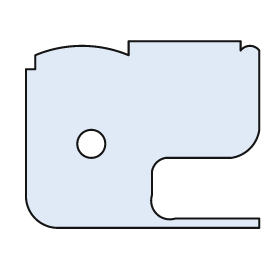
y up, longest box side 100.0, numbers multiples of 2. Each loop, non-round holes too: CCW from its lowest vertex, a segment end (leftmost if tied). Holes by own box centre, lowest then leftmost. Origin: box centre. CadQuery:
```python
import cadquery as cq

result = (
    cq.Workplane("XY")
    .moveTo(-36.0, -40.0)
    .lineTo(50.0, -40.0)
    .lineTo(50.0, -36.0)
    .lineTo(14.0, -36.0)
    .threePointArc((6.0, -34.0), (4.0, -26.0))
    .lineTo(4.0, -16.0)
    .threePointArc((6.0, -12.0), (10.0, -10.0))
    .lineTo(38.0, -10.0)
    .threePointArc((46.0, -6.0), (50.0, 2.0))
    .lineTo(50.0, 36.0)
    .threePointArc((46.0, 38.0), (42.0, 36.0))
    .lineTo(42.0, 40.0)
    .lineTo(-6.0, 40.0)
    .lineTo(-6.0, 34.0)
    .threePointArc((-26.0, 38.0), (-46.0, 34.0))
    .lineTo(-46.0, 28.0)
    .lineTo(-50.0, 28.0)
    .lineTo(-50.0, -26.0)
    .threePointArc((-46.0, -36.0), (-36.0, -40.0))
    .close()
    .moveTo(-22.0, -4.0)
    .circle(6.0)
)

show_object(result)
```